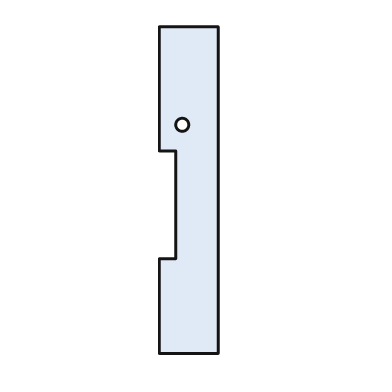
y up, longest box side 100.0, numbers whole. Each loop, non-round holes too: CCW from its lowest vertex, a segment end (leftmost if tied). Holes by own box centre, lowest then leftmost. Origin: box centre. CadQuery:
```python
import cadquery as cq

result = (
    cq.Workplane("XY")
    .moveTo(-9.0, -50.0)
    .lineTo(9.0, -50.0)
    .lineTo(9.0, 50.0)
    .lineTo(-9.0, 50.0)
    .lineTo(-9.0, 12.0)
    .lineTo(-4.0, 12.0)
    .lineTo(-4.0, -21.0)
    .lineTo(-9.0, -21.0)
    .close()
    .moveTo(-2.0, 20.0)
    .circle(2.0)
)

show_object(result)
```